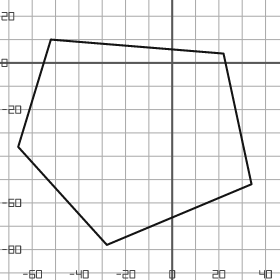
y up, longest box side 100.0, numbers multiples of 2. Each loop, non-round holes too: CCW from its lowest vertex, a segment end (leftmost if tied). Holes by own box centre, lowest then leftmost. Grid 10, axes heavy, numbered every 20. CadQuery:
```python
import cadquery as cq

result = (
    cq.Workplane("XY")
    .moveTo(-28.0, -78.0)
    .lineTo(34.0, -52.0)
    .lineTo(22.0, 4.0)
    .lineTo(-52.0, 10.0)
    .lineTo(-66.0, -36.0)
    .close()
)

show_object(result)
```